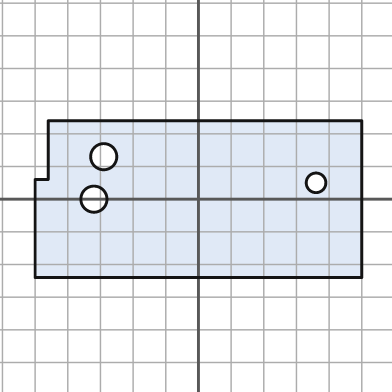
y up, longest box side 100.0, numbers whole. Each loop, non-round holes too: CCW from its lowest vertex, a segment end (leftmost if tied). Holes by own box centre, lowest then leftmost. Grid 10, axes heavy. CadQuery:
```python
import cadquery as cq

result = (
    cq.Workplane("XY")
    .moveTo(-50.0, -24.0)
    .lineTo(50.0, -24.0)
    .lineTo(50.0, 24.0)
    .lineTo(-46.0, 24.0)
    .lineTo(-46.0, 6.0)
    .lineTo(-50.0, 6.0)
    .close()
    .moveTo(-32.0, 0.0)
    .circle(4.0)
    .moveTo(36.0, 5.0)
    .circle(3.0)
    .moveTo(-29.0, 13.0)
    .circle(4.0)
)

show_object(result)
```